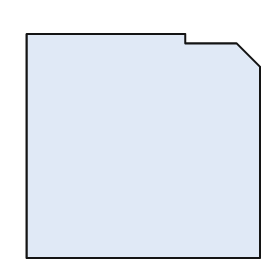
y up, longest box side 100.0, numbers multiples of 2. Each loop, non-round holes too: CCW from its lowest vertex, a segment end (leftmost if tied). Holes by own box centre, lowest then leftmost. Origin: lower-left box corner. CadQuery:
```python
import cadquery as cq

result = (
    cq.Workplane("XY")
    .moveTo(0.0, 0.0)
    .lineTo(100.0, 0.0)
    .lineTo(100.0, 82.0)
    .lineTo(90.0, 92.0)
    .lineTo(68.0, 92.0)
    .lineTo(68.0, 96.0)
    .lineTo(0.0, 96.0)
    .close()
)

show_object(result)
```